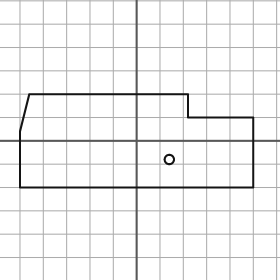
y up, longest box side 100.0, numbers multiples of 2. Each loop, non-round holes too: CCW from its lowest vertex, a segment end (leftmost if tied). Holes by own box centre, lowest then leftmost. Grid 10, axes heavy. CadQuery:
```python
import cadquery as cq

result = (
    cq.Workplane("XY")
    .moveTo(-50.0, -20.0)
    .lineTo(50.0, -20.0)
    .lineTo(50.0, 10.0)
    .lineTo(22.0, 10.0)
    .lineTo(22.0, 20.0)
    .lineTo(-46.0, 20.0)
    .lineTo(-50.0, 4.0)
    .close()
    .moveTo(14.0, -8.0)
    .circle(2.0)
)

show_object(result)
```